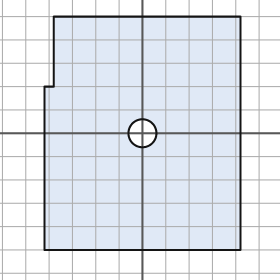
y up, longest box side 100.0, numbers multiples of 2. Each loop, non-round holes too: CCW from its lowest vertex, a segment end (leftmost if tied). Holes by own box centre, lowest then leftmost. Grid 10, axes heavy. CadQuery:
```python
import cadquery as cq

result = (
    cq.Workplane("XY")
    .moveTo(-42.0, -50.0)
    .lineTo(42.0, -50.0)
    .lineTo(42.0, 50.0)
    .lineTo(-38.0, 50.0)
    .lineTo(-38.0, 20.0)
    .lineTo(-42.0, 20.0)
    .close()
    .moveTo(0.0, 0.0)
    .circle(6.0)
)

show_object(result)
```